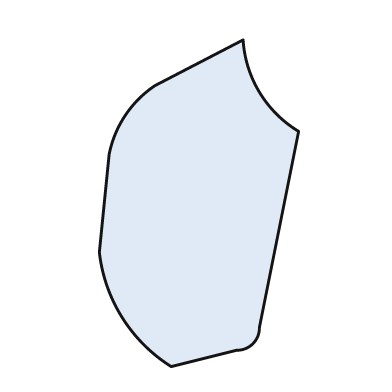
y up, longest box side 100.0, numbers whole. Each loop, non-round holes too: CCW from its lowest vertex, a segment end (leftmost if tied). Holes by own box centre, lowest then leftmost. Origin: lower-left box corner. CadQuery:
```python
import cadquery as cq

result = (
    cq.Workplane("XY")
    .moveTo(22.0, 0.0)
    .lineTo(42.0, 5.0)
    .threePointArc((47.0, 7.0), (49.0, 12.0))
    .lineTo(61.0, 72.0)
    .threePointArc((49.0, 84.0), (44.0, 100.0))
    .lineTo(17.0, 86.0)
    .threePointArc((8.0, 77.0), (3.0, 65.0))
    .lineTo(0.0, 35.0)
    .threePointArc((7.0, 15.0), (22.0, 0.0))
    .close()
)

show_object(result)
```